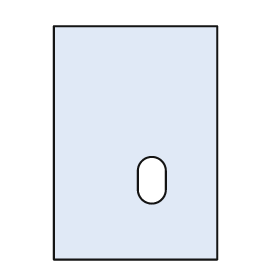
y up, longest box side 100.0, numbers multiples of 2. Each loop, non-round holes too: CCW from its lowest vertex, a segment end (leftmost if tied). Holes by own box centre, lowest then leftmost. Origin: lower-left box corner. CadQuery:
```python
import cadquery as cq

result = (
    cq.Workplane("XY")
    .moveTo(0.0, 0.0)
    .lineTo(70.0, 0.0)
    .lineTo(70.0, 100.0)
    .lineTo(0.0, 100.0)
    .close()
    .moveTo(36.0, 30.0)
    .threePointArc((42.0, 24.0), (48.0, 30.0))
    .lineTo(48.0, 38.0)
    .threePointArc((42.0, 44.0), (36.0, 38.0))
    .close()
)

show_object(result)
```